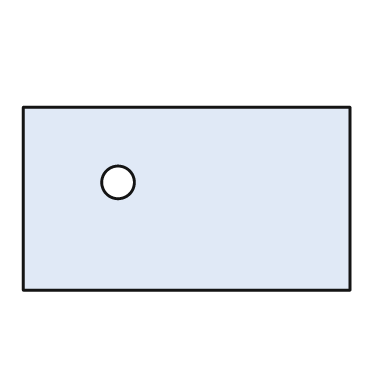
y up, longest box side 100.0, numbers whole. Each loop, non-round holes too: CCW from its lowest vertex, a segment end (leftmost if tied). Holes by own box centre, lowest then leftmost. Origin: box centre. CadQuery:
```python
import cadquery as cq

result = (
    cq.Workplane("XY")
    .moveTo(-50.0, -28.0)
    .lineTo(50.0, -28.0)
    .lineTo(50.0, 28.0)
    .lineTo(-50.0, 28.0)
    .close()
    .moveTo(-21.0, 5.0)
    .circle(5.0)
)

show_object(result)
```